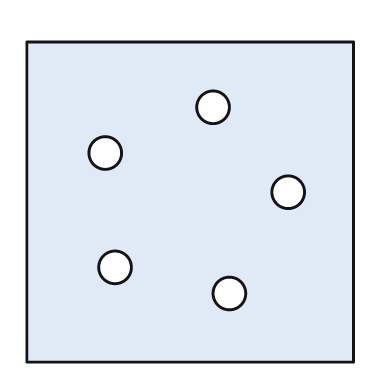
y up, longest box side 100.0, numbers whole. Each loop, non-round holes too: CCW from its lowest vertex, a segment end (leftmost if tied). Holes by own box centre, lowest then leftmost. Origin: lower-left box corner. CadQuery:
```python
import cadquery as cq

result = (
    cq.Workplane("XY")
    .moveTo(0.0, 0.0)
    .lineTo(100.0, 0.0)
    .lineTo(100.0, 98.0)
    .lineTo(0.0, 98.0)
    .close()
    .moveTo(62.0, 21.0)
    .circle(5.0)
    .moveTo(27.0, 29.0)
    .circle(5.0)
    .moveTo(80.0, 52.0)
    .circle(5.0)
    .moveTo(24.0, 64.0)
    .circle(5.0)
    .moveTo(57.0, 78.0)
    .circle(5.0)
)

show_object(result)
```